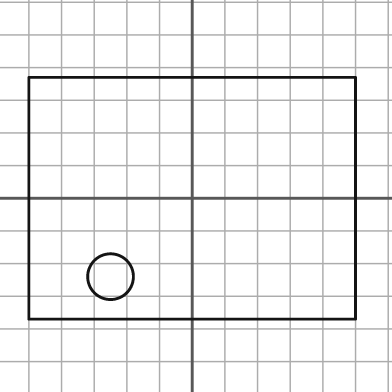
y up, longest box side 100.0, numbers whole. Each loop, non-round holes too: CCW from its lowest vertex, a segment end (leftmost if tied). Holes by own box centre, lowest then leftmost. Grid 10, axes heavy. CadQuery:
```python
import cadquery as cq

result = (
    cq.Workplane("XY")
    .moveTo(-50.0, -37.0)
    .lineTo(50.0, -37.0)
    .lineTo(50.0, 37.0)
    .lineTo(-50.0, 37.0)
    .close()
    .moveTo(-25.0, -24.0)
    .circle(7.0)
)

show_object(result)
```